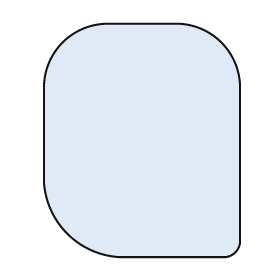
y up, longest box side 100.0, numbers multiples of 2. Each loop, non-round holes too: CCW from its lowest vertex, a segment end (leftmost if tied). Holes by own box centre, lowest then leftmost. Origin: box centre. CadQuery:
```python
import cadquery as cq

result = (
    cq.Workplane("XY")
    .moveTo(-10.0, -50.0)
    .lineTo(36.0, -50.0)
    .threePointArc((40.0, -48.0), (42.0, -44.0))
    .lineTo(42.0, 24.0)
    .threePointArc((34.0, 42.0), (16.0, 50.0))
    .lineTo(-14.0, 50.0)
    .threePointArc((-34.0, 42.0), (-42.0, 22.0))
    .lineTo(-42.0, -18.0)
    .threePointArc((-32.0, -40.0), (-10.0, -50.0))
    .close()
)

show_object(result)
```